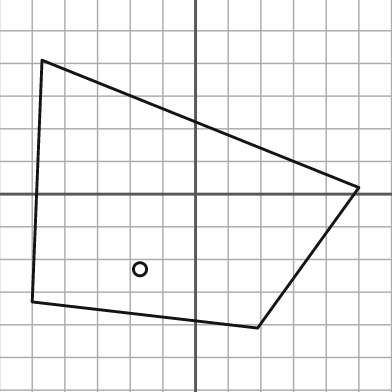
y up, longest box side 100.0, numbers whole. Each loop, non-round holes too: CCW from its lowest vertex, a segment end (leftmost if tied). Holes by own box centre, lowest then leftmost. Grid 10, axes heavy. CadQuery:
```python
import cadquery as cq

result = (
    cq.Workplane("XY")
    .moveTo(19.0, -41.0)
    .lineTo(50.0, 2.0)
    .lineTo(-47.0, 41.0)
    .lineTo(-50.0, -33.0)
    .close()
    .moveTo(-17.0, -23.0)
    .circle(2.0)
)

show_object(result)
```